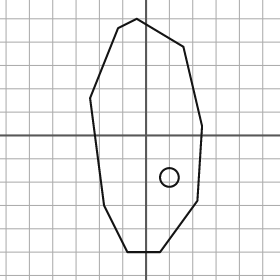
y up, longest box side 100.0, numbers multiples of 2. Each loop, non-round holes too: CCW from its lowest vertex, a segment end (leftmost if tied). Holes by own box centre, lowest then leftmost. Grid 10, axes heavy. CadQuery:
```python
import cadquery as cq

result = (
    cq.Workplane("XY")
    .moveTo(-8.0, -50.0)
    .lineTo(6.0, -50.0)
    .lineTo(22.0, -28.0)
    .lineTo(24.0, 4.0)
    .lineTo(16.0, 38.0)
    .lineTo(-4.0, 50.0)
    .lineTo(-12.0, 46.0)
    .lineTo(-24.0, 16.0)
    .lineTo(-18.0, -30.0)
    .close()
    .moveTo(10.0, -18.0)
    .circle(4.0)
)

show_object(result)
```